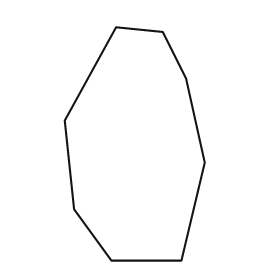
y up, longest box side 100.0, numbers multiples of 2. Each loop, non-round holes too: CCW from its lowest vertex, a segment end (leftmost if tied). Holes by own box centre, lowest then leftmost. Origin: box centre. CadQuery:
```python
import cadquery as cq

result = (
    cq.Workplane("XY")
    .moveTo(-10.0, -50.0)
    .lineTo(20.0, -50.0)
    .lineTo(30.0, -8.0)
    .lineTo(22.0, 28.0)
    .lineTo(12.0, 48.0)
    .lineTo(-8.0, 50.0)
    .lineTo(-30.0, 10.0)
    .lineTo(-26.0, -28.0)
    .close()
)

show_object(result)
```